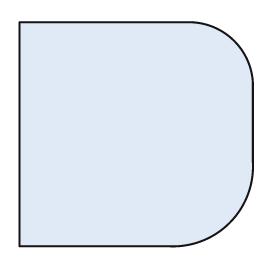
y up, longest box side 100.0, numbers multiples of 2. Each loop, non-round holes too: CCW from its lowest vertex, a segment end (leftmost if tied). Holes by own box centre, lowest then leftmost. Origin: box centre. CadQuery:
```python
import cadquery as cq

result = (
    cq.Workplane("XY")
    .moveTo(-50.0, -48.0)
    .lineTo(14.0, -48.0)
    .threePointArc((40.0, -38.0), (50.0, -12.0))
    .lineTo(50.0, 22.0)
    .threePointArc((42.0, 40.0), (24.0, 48.0))
    .lineTo(-50.0, 48.0)
    .close()
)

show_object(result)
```